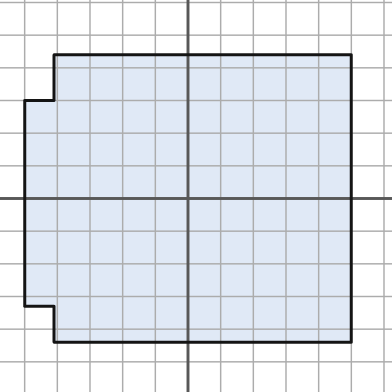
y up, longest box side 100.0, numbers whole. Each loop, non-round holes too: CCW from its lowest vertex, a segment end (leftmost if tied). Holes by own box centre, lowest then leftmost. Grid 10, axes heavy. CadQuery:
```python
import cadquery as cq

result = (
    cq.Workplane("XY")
    .moveTo(-41.0, -44.0)
    .lineTo(50.0, -44.0)
    .lineTo(50.0, 44.0)
    .lineTo(-41.0, 44.0)
    .lineTo(-41.0, 30.0)
    .lineTo(-50.0, 30.0)
    .lineTo(-50.0, -33.0)
    .lineTo(-41.0, -33.0)
    .close()
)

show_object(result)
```